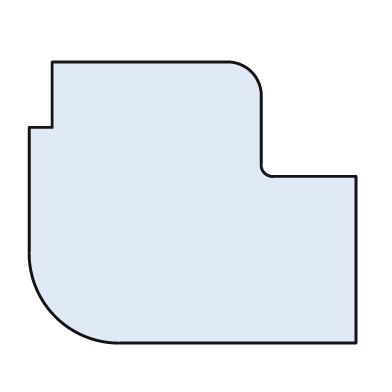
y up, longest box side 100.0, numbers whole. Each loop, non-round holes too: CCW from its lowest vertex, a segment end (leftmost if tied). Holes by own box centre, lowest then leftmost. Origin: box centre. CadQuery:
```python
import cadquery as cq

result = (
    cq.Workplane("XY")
    .moveTo(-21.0, -43.0)
    .lineTo(50.0, -43.0)
    .lineTo(50.0, 8.0)
    .lineTo(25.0, 8.0)
    .threePointArc((22.0, 9.0), (21.0, 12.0))
    .lineTo(21.0, 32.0)
    .threePointArc((18.0, 40.0), (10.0, 43.0))
    .lineTo(-43.0, 43.0)
    .lineTo(-43.0, 23.0)
    .lineTo(-50.0, 23.0)
    .lineTo(-50.0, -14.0)
    .threePointArc((-42.0, -35.0), (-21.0, -43.0))
    .close()
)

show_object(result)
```